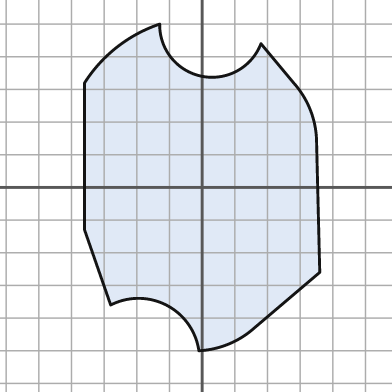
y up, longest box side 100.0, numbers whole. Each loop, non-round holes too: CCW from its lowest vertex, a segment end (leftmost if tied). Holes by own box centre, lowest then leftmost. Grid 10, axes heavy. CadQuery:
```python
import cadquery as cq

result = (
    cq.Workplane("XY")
    .moveTo(-1.0, -50.0)
    .threePointArc((8.0, -48.0), (16.0, -43.0))
    .lineTo(36.0, -26.0)
    .lineTo(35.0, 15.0)
    .threePointArc((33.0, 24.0), (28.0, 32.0))
    .lineTo(18.0, 44.0)
    .threePointArc((0.0, 34.0), (-13.0, 50.0))
    .threePointArc((-26.0, 43.0), (-36.0, 32.0))
    .lineTo(-36.0, -13.0)
    .lineTo(-28.0, -36.0)
    .threePointArc((-11.0, -36.0), (-1.0, -50.0))
    .close()
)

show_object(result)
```